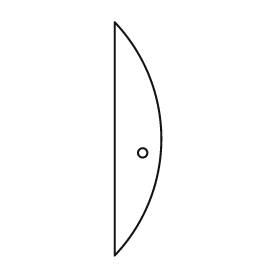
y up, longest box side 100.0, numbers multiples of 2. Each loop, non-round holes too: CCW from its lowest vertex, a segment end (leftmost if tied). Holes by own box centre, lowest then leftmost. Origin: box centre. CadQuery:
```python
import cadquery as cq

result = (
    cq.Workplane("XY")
    .moveTo(-10.0, -50.0)
    .threePointArc((10.0, 0.0), (-10.0, 50.0))
    .close()
    .moveTo(2.0, -6.0)
    .circle(2.0)
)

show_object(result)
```